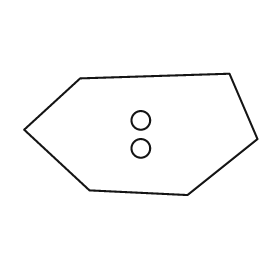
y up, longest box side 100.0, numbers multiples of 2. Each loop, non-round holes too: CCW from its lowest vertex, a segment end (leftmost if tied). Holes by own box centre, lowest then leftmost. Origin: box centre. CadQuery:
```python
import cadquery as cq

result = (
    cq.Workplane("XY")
    .moveTo(20.0, -26.0)
    .lineTo(50.0, -2.0)
    .lineTo(38.0, 26.0)
    .lineTo(-26.0, 24.0)
    .lineTo(-50.0, 2.0)
    .lineTo(-22.0, -24.0)
    .close()
    .moveTo(0.0, -6.0)
    .circle(4.0)
    .moveTo(0.0, 6.0)
    .circle(4.0)
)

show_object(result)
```